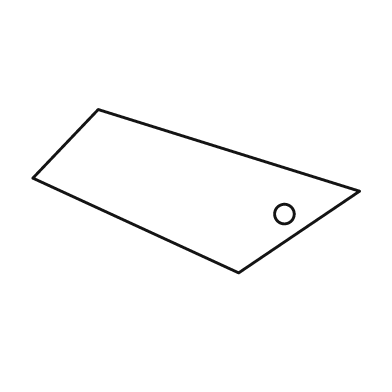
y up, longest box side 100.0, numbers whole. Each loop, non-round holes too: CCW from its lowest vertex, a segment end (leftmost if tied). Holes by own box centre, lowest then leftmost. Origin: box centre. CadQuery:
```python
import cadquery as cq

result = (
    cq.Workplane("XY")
    .moveTo(13.0, -25.0)
    .lineTo(50.0, 0.0)
    .lineTo(-30.0, 25.0)
    .lineTo(-50.0, 4.0)
    .close()
    .moveTo(27.0, -7.0)
    .circle(3.0)
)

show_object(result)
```